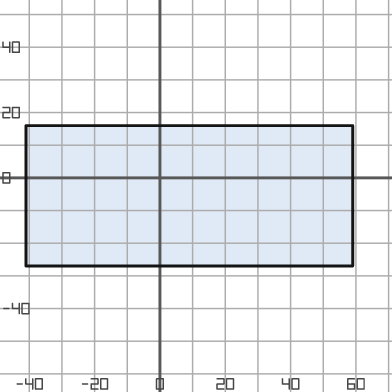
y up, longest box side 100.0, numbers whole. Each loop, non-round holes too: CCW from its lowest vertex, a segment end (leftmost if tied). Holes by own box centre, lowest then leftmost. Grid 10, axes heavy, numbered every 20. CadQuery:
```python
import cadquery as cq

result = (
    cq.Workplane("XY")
    .moveTo(-41.0, -27.0)
    .lineTo(59.0, -27.0)
    .lineTo(59.0, 16.0)
    .lineTo(-41.0, 16.0)
    .close()
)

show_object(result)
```